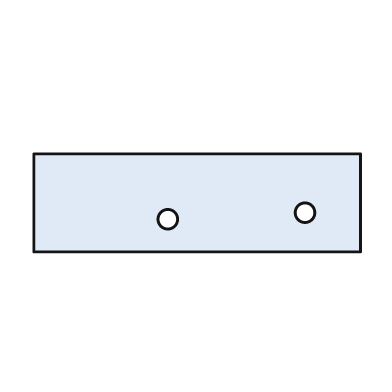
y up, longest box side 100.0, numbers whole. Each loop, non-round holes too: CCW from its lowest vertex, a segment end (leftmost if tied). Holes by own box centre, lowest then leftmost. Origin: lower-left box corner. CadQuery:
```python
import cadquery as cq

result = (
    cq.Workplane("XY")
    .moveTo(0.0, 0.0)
    .lineTo(100.0, 0.0)
    .lineTo(100.0, 30.0)
    .lineTo(0.0, 30.0)
    .close()
    .moveTo(41.0, 10.0)
    .circle(3.0)
    .moveTo(83.0, 12.0)
    .circle(3.0)
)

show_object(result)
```